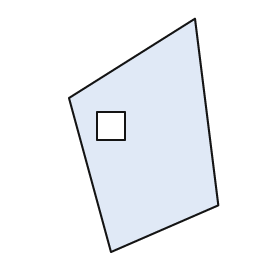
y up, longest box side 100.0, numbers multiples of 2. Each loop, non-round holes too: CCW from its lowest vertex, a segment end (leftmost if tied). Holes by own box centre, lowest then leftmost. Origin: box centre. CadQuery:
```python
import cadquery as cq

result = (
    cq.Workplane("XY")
    .moveTo(-14.0, -50.0)
    .lineTo(32.0, -30.0)
    .lineTo(22.0, 50.0)
    .lineTo(-32.0, 16.0)
    .close()
    .moveTo(-20.0, -2.0)
    .lineTo(-8.0, -2.0)
    .lineTo(-8.0, 10.0)
    .lineTo(-20.0, 10.0)
    .close()
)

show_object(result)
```